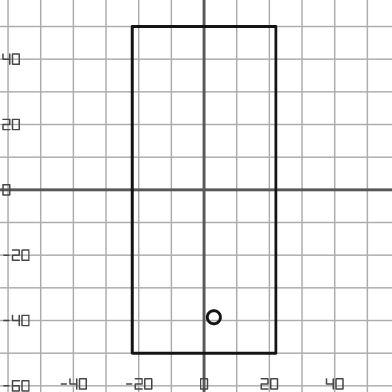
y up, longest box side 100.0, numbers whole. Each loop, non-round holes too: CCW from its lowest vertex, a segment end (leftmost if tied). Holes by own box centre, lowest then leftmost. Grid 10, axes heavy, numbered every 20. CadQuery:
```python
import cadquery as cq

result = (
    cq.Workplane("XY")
    .moveTo(-22.0, -50.0)
    .lineTo(22.0, -50.0)
    .lineTo(22.0, 50.0)
    .lineTo(-22.0, 50.0)
    .close()
    .moveTo(3.0, -39.0)
    .circle(2.0)
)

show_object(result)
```